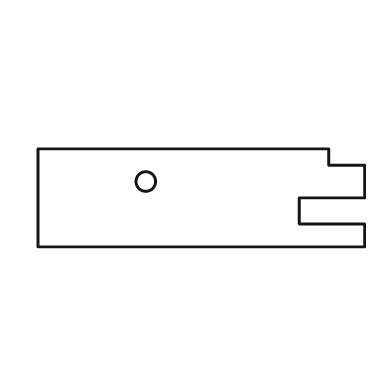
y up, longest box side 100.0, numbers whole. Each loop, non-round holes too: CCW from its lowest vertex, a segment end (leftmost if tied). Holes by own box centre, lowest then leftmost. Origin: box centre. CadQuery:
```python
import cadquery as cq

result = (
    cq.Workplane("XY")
    .moveTo(-50.0, -15.0)
    .lineTo(50.0, -15.0)
    .lineTo(50.0, -8.0)
    .lineTo(30.0, -8.0)
    .lineTo(30.0, 0.0)
    .lineTo(50.0, 0.0)
    .lineTo(50.0, 10.0)
    .lineTo(39.0, 10.0)
    .lineTo(39.0, 15.0)
    .lineTo(-50.0, 15.0)
    .close()
    .moveTo(-17.0, 5.0)
    .circle(3.0)
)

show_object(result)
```